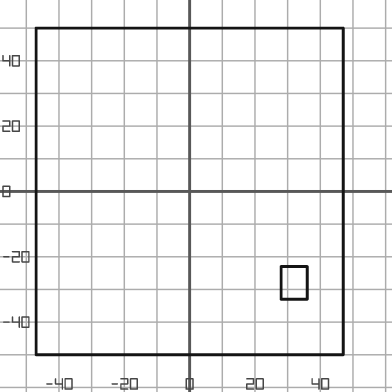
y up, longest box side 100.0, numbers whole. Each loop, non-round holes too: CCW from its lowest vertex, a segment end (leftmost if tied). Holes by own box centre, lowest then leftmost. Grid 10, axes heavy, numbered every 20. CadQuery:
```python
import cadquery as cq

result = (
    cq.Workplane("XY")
    .moveTo(-47.0, -50.0)
    .lineTo(47.0, -50.0)
    .lineTo(47.0, 50.0)
    .lineTo(-47.0, 50.0)
    .close()
    .moveTo(28.0, -33.0)
    .lineTo(36.0, -33.0)
    .lineTo(36.0, -23.0)
    .lineTo(28.0, -23.0)
    .close()
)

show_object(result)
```